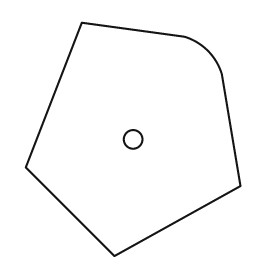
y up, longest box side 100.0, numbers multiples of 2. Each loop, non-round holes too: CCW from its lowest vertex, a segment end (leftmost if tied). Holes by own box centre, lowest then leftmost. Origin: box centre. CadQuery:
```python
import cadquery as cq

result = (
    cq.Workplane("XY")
    .moveTo(-8.0, -50.0)
    .lineTo(46.0, -20.0)
    .lineTo(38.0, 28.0)
    .threePointArc((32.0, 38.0), (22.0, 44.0))
    .lineTo(-22.0, 50.0)
    .lineTo(-46.0, -12.0)
    .close()
    .moveTo(0.0, 0.0)
    .circle(4.0)
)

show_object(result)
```